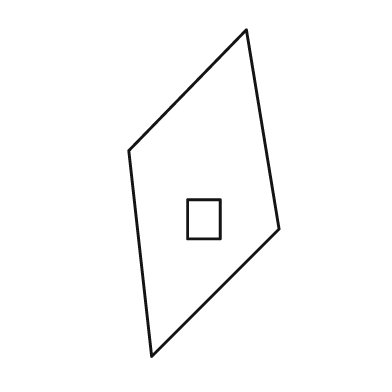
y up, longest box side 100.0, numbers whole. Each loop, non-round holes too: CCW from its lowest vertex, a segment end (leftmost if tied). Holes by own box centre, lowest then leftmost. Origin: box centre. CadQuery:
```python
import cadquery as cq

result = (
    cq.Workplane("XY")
    .moveTo(-16.0, -50.0)
    .lineTo(23.0, -11.0)
    .lineTo(13.0, 50.0)
    .lineTo(-23.0, 13.0)
    .close()
    .moveTo(-5.0, -14.0)
    .lineTo(5.0, -14.0)
    .lineTo(5.0, -2.0)
    .lineTo(-5.0, -2.0)
    .close()
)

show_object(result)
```